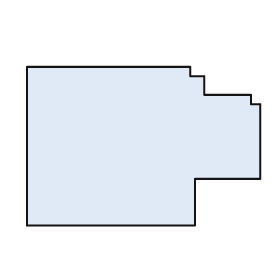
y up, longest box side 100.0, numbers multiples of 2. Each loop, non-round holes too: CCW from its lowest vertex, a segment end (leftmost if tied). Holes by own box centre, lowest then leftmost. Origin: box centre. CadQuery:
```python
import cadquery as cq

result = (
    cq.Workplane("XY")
    .moveTo(-50.0, -34.0)
    .lineTo(22.0, -34.0)
    .lineTo(22.0, -14.0)
    .lineTo(50.0, -14.0)
    .lineTo(50.0, 18.0)
    .lineTo(46.0, 18.0)
    .lineTo(46.0, 22.0)
    .lineTo(26.0, 22.0)
    .lineTo(26.0, 30.0)
    .lineTo(20.0, 30.0)
    .lineTo(20.0, 34.0)
    .lineTo(-50.0, 34.0)
    .close()
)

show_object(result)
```